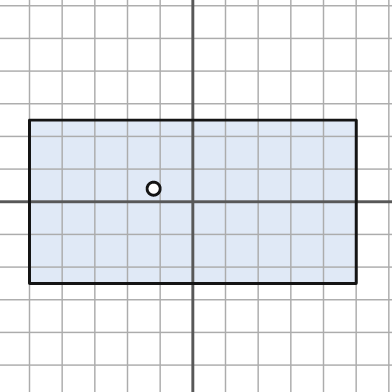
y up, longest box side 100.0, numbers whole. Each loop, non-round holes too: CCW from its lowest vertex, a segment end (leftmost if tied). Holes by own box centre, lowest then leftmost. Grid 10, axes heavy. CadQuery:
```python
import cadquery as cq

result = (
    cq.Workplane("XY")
    .moveTo(-50.0, -25.0)
    .lineTo(50.0, -25.0)
    .lineTo(50.0, 25.0)
    .lineTo(-50.0, 25.0)
    .close()
    .moveTo(-12.0, 4.0)
    .circle(2.0)
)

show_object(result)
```